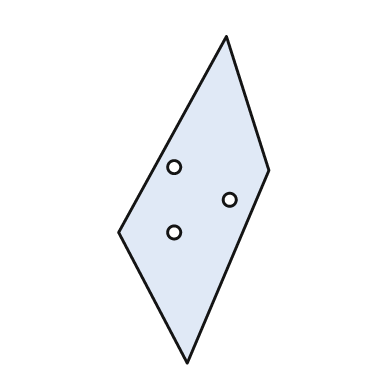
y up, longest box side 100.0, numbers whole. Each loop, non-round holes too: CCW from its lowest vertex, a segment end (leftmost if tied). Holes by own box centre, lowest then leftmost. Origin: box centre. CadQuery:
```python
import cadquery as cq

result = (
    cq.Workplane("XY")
    .moveTo(-2.0, -50.0)
    .lineTo(23.0, 9.0)
    .lineTo(10.0, 50.0)
    .lineTo(-23.0, -10.0)
    .close()
    .moveTo(-6.0, -10.0)
    .circle(2.0)
    .moveTo(11.0, 0.0)
    .circle(2.0)
    .moveTo(-6.0, 10.0)
    .circle(2.0)
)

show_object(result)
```